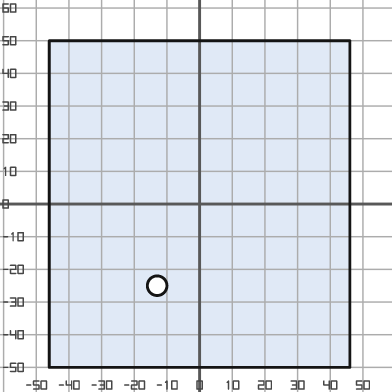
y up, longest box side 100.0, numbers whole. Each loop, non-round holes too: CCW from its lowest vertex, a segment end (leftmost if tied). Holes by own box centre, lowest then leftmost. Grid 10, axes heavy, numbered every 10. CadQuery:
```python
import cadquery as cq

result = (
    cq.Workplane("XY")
    .moveTo(-46.0, -50.0)
    .lineTo(46.0, -50.0)
    .lineTo(46.0, 50.0)
    .lineTo(-46.0, 50.0)
    .close()
    .moveTo(-13.0, -25.0)
    .circle(3.0)
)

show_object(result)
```